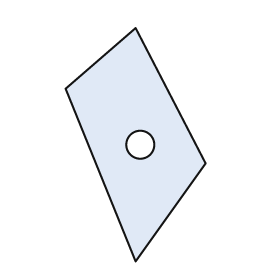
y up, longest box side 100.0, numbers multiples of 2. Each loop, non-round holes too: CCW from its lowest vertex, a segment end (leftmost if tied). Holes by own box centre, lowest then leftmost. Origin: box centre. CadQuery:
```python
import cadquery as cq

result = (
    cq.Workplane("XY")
    .moveTo(0.0, -50.0)
    .lineTo(30.0, -8.0)
    .lineTo(0.0, 50.0)
    .lineTo(-30.0, 24.0)
    .close()
    .moveTo(2.0, 0.0)
    .circle(6.0)
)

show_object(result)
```